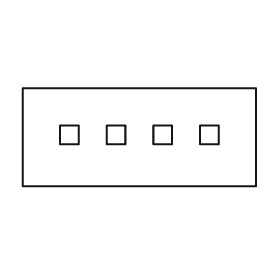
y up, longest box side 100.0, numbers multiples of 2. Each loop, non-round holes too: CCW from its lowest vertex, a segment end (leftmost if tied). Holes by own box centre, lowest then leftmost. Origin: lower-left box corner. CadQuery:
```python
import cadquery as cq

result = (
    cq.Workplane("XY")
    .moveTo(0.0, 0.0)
    .lineTo(100.0, 0.0)
    .lineTo(100.0, 42.0)
    .lineTo(0.0, 42.0)
    .close()
    .moveTo(16.0, 18.0)
    .lineTo(24.0, 18.0)
    .lineTo(24.0, 26.0)
    .lineTo(16.0, 26.0)
    .close()
    .moveTo(36.0, 18.0)
    .lineTo(44.0, 18.0)
    .lineTo(44.0, 26.0)
    .lineTo(36.0, 26.0)
    .close()
    .moveTo(56.0, 18.0)
    .lineTo(64.0, 18.0)
    .lineTo(64.0, 26.0)
    .lineTo(56.0, 26.0)
    .close()
    .moveTo(76.0, 18.0)
    .lineTo(84.0, 18.0)
    .lineTo(84.0, 26.0)
    .lineTo(76.0, 26.0)
    .close()
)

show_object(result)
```